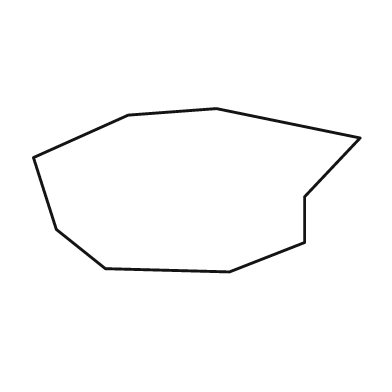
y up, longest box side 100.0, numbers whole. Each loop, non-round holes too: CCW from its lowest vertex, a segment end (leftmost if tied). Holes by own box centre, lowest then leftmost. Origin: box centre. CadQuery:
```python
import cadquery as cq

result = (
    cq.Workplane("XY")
    .moveTo(10.0, -25.0)
    .lineTo(33.0, -16.0)
    .lineTo(33.0, -2.0)
    .lineTo(50.0, 16.0)
    .lineTo(6.0, 25.0)
    .lineTo(-21.0, 23.0)
    .lineTo(-50.0, 10.0)
    .lineTo(-43.0, -12.0)
    .lineTo(-28.0, -24.0)
    .close()
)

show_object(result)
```